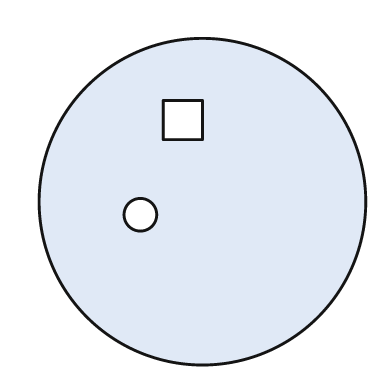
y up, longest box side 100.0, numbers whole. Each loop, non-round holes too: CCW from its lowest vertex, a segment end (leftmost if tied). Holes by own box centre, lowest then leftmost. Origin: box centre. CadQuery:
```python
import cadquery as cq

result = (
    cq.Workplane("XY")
    .moveTo(0.0, 0.0)
    .circle(50.0)
    .moveTo(-19.0, -4.0)
    .circle(5.0)
    .moveTo(-12.0, 19.0)
    .lineTo(0.0, 19.0)
    .lineTo(0.0, 31.0)
    .lineTo(-12.0, 31.0)
    .close()
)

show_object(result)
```